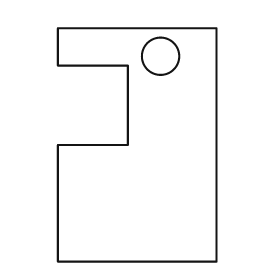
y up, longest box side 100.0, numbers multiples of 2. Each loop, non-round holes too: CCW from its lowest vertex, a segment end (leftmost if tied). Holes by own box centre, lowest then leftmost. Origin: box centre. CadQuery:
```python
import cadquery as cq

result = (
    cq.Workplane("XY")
    .moveTo(-34.0, -50.0)
    .lineTo(34.0, -50.0)
    .lineTo(34.0, 50.0)
    .lineTo(-34.0, 50.0)
    .lineTo(-34.0, 34.0)
    .lineTo(-4.0, 34.0)
    .lineTo(-4.0, 0.0)
    .lineTo(-34.0, 0.0)
    .close()
    .moveTo(10.0, 38.0)
    .circle(8.0)
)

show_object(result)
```